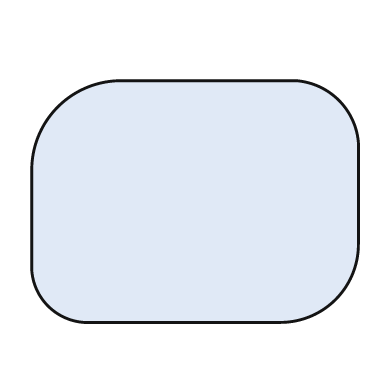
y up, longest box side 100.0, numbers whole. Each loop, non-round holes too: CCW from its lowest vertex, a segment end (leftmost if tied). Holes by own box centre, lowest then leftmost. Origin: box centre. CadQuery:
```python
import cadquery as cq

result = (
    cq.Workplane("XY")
    .moveTo(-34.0, -37.0)
    .lineTo(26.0, -37.0)
    .threePointArc((43.0, -30.0), (50.0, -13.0))
    .lineTo(50.0, 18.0)
    .threePointArc((44.0, 31.0), (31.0, 37.0))
    .lineTo(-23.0, 37.0)
    .threePointArc((-42.0, 29.0), (-50.0, 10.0))
    .lineTo(-50.0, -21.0)
    .threePointArc((-45.0, -32.0), (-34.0, -37.0))
    .close()
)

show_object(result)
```